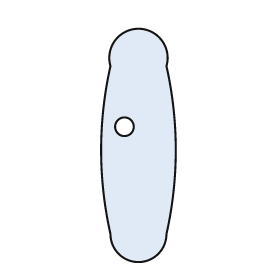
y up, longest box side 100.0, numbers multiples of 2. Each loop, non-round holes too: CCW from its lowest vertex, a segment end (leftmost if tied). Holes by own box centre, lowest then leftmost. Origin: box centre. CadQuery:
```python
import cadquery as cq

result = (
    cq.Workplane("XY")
    .moveTo(-12.0, -38.0)
    .threePointArc((0.0, -50.0), (12.0, -38.0))
    .threePointArc((16.0, -2.0), (12.0, 34.0))
    .threePointArc((0.0, 50.0), (-12.0, 34.0))
    .threePointArc((-16.0, -2.0), (-12.0, -38.0))
    .close()
    .moveTo(-6.0, 8.0)
    .circle(4.0)
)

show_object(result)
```